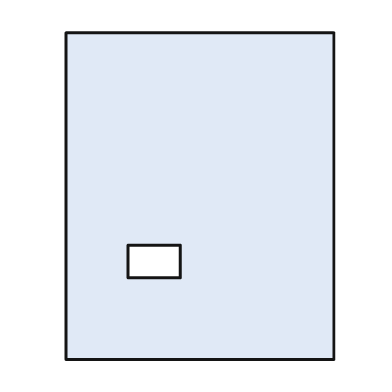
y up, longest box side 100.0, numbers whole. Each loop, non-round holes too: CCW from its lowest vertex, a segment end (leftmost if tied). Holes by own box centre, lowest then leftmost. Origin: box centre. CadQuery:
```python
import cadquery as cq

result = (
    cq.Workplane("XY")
    .moveTo(-41.0, -50.0)
    .lineTo(41.0, -50.0)
    .lineTo(41.0, 50.0)
    .lineTo(-41.0, 50.0)
    .close()
    .moveTo(-22.0, -25.0)
    .lineTo(-6.0, -25.0)
    .lineTo(-6.0, -15.0)
    .lineTo(-22.0, -15.0)
    .close()
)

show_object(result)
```